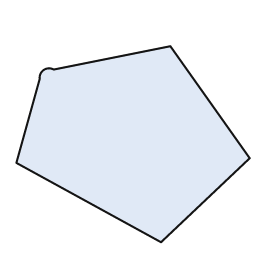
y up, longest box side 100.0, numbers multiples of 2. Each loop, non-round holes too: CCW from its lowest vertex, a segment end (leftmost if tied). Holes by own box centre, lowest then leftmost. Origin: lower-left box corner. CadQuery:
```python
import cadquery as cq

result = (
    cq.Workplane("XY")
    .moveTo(62.0, 0.0)
    .lineTo(100.0, 36.0)
    .lineTo(66.0, 84.0)
    .lineTo(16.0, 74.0)
    .threePointArc((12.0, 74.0), (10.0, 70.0))
    .lineTo(0.0, 34.0)
    .close()
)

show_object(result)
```